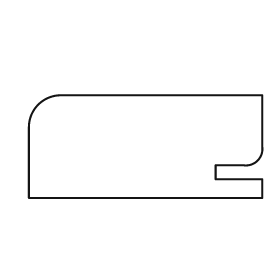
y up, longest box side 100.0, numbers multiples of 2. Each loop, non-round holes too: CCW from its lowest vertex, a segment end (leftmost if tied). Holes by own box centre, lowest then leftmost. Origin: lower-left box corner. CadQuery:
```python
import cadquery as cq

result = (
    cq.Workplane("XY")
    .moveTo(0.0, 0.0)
    .lineTo(100.0, 0.0)
    .lineTo(100.0, 8.0)
    .lineTo(80.0, 8.0)
    .lineTo(80.0, 14.0)
    .lineTo(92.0, 14.0)
    .threePointArc((98.0, 16.0), (100.0, 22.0))
    .lineTo(100.0, 44.0)
    .lineTo(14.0, 44.0)
    .threePointArc((4.0, 40.0), (0.0, 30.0))
    .close()
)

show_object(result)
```